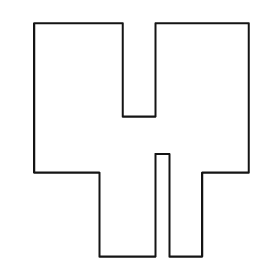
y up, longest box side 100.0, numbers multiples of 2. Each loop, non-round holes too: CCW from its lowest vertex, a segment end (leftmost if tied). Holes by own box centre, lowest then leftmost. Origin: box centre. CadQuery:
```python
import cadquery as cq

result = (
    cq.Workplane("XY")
    .moveTo(-18.0, -50.0)
    .lineTo(6.0, -50.0)
    .lineTo(6.0, -6.0)
    .lineTo(12.0, -6.0)
    .lineTo(12.0, -50.0)
    .lineTo(26.0, -50.0)
    .lineTo(26.0, -14.0)
    .lineTo(46.0, -14.0)
    .lineTo(46.0, 50.0)
    .lineTo(6.0, 50.0)
    .lineTo(6.0, 10.0)
    .lineTo(-8.0, 10.0)
    .lineTo(-8.0, 50.0)
    .lineTo(-46.0, 50.0)
    .lineTo(-46.0, -14.0)
    .lineTo(-18.0, -14.0)
    .close()
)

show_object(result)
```